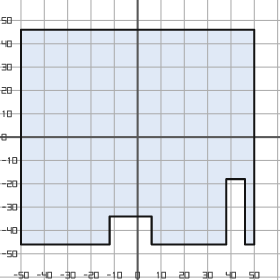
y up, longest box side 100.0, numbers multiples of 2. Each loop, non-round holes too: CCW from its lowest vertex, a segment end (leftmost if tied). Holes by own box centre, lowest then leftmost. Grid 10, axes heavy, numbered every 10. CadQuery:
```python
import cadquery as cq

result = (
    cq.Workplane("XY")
    .moveTo(-50.0, -46.0)
    .lineTo(-12.0, -46.0)
    .lineTo(-12.0, -34.0)
    .lineTo(6.0, -34.0)
    .lineTo(6.0, -46.0)
    .lineTo(38.0, -46.0)
    .lineTo(38.0, -18.0)
    .lineTo(46.0, -18.0)
    .lineTo(46.0, -46.0)
    .lineTo(50.0, -46.0)
    .lineTo(50.0, 46.0)
    .lineTo(-50.0, 46.0)
    .close()
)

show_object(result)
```